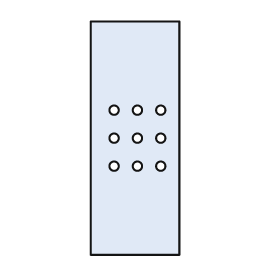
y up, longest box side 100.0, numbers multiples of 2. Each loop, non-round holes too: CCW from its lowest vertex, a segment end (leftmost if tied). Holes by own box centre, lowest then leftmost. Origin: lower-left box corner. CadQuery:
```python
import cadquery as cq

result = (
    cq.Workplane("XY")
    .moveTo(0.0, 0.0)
    .lineTo(38.0, 0.0)
    .lineTo(38.0, 100.0)
    .lineTo(0.0, 100.0)
    .close()
    .moveTo(10.0, 38.0)
    .circle(2.0)
    .moveTo(20.0, 38.0)
    .circle(2.0)
    .moveTo(30.0, 38.0)
    .circle(2.0)
    .moveTo(10.0, 50.0)
    .circle(2.0)
    .moveTo(20.0, 50.0)
    .circle(2.0)
    .moveTo(30.0, 50.0)
    .circle(2.0)
    .moveTo(10.0, 62.0)
    .circle(2.0)
    .moveTo(20.0, 62.0)
    .circle(2.0)
    .moveTo(30.0, 62.0)
    .circle(2.0)
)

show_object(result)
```